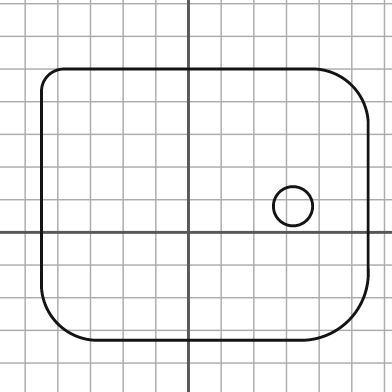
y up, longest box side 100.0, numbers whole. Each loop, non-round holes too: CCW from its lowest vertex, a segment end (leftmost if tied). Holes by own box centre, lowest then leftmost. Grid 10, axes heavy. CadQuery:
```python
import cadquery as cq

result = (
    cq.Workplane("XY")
    .moveTo(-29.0, -33.0)
    .lineTo(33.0, -33.0)
    .threePointArc((49.0, -27.0), (55.0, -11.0))
    .lineTo(55.0, 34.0)
    .threePointArc((50.0, 45.0), (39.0, 50.0))
    .lineTo(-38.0, 50.0)
    .threePointArc((-43.0, 48.0), (-45.0, 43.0))
    .lineTo(-45.0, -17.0)
    .threePointArc((-40.0, -28.0), (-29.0, -33.0))
    .close()
    .moveTo(32.0, 8.0)
    .circle(6.0)
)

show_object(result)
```